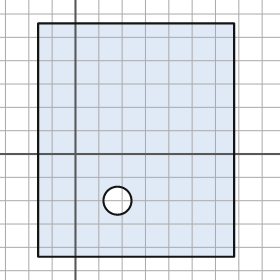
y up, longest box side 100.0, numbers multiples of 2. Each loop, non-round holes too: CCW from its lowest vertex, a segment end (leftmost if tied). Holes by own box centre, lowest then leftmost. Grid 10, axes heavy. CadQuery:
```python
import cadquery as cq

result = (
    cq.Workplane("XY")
    .moveTo(-16.0, -44.0)
    .lineTo(68.0, -44.0)
    .lineTo(68.0, 56.0)
    .lineTo(-16.0, 56.0)
    .close()
    .moveTo(18.0, -20.0)
    .circle(6.0)
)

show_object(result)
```